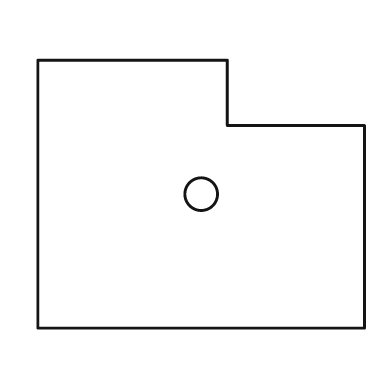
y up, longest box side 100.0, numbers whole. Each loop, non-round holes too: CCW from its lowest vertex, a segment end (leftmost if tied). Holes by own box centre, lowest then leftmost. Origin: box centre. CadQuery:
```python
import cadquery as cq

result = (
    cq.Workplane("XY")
    .moveTo(-50.0, -41.0)
    .lineTo(50.0, -41.0)
    .lineTo(50.0, 21.0)
    .lineTo(8.0, 21.0)
    .lineTo(8.0, 41.0)
    .lineTo(-50.0, 41.0)
    .close()
    .moveTo(0.0, 0.0)
    .circle(5.0)
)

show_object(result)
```